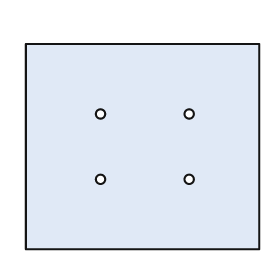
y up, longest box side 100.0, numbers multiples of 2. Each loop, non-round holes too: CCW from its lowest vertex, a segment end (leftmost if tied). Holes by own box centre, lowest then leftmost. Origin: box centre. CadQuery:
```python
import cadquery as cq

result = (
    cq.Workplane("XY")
    .moveTo(-50.0, -44.0)
    .lineTo(50.0, -44.0)
    .lineTo(50.0, 44.0)
    .lineTo(-50.0, 44.0)
    .close()
    .moveTo(-18.0, -14.0)
    .circle(2.0)
    .moveTo(20.0, -14.0)
    .circle(2.0)
    .moveTo(-18.0, 14.0)
    .circle(2.0)
    .moveTo(20.0, 14.0)
    .circle(2.0)
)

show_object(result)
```